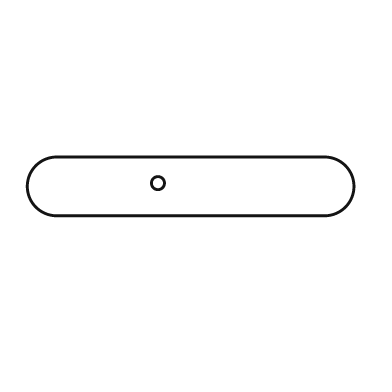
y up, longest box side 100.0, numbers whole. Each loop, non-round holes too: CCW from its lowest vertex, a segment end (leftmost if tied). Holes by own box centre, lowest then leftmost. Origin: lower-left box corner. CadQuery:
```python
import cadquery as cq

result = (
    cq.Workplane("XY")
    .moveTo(9.0, 0.0)
    .lineTo(91.0, 0.0)
    .threePointArc((100.0, 9.0), (91.0, 18.0))
    .lineTo(9.0, 18.0)
    .threePointArc((0.0, 9.0), (9.0, 0.0))
    .close()
    .moveTo(40.0, 10.0)
    .circle(2.0)
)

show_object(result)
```